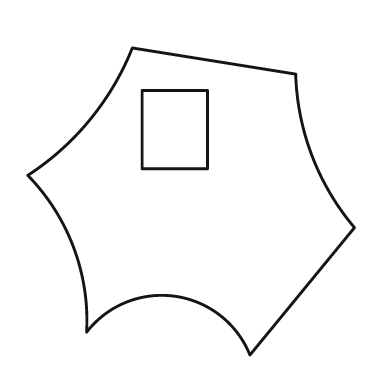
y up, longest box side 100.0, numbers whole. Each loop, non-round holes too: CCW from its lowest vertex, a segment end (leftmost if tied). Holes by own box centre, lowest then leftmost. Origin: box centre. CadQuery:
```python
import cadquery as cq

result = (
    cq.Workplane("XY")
    .moveTo(18.0, -47.0)
    .lineTo(50.0, -8.0)
    .threePointArc((37.0, 14.0), (32.0, 39.0))
    .lineTo(-18.0, 47.0)
    .threePointArc((-31.0, 25.0), (-50.0, 8.0))
    .threePointArc((-36.0, -14.0), (-32.0, -40.0))
    .threePointArc((-5.0, -29.0), (18.0, -47.0))
    .close()
    .moveTo(-15.0, 10.0)
    .lineTo(5.0, 10.0)
    .lineTo(5.0, 34.0)
    .lineTo(-15.0, 34.0)
    .close()
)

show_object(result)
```